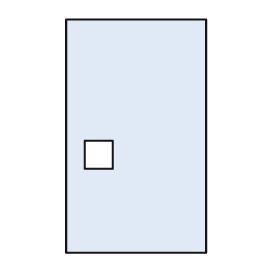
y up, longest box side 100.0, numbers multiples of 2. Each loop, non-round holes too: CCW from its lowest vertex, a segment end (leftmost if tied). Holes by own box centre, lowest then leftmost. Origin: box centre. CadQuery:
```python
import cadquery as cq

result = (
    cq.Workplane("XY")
    .moveTo(-30.0, -50.0)
    .lineTo(30.0, -50.0)
    .lineTo(30.0, 50.0)
    .lineTo(-30.0, 50.0)
    .close()
    .moveTo(-22.0, -14.0)
    .lineTo(-10.0, -14.0)
    .lineTo(-10.0, -2.0)
    .lineTo(-22.0, -2.0)
    .close()
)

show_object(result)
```